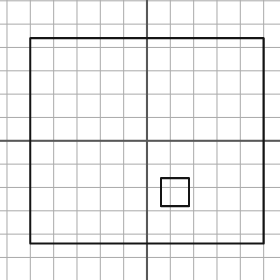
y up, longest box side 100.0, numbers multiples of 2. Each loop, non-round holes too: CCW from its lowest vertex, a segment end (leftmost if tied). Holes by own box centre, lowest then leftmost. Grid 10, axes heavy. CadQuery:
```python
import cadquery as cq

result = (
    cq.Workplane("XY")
    .moveTo(-50.0, -44.0)
    .lineTo(50.0, -44.0)
    .lineTo(50.0, 44.0)
    .lineTo(-50.0, 44.0)
    .close()
    .moveTo(6.0, -28.0)
    .lineTo(18.0, -28.0)
    .lineTo(18.0, -16.0)
    .lineTo(6.0, -16.0)
    .close()
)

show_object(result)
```